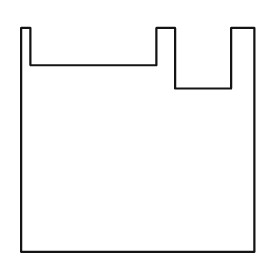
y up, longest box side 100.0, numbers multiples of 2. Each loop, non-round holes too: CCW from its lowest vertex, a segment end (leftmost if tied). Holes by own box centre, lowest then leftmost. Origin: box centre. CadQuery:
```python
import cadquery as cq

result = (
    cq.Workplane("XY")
    .moveTo(-50.0, -48.0)
    .lineTo(50.0, -48.0)
    .lineTo(50.0, 48.0)
    .lineTo(40.0, 48.0)
    .lineTo(40.0, 22.0)
    .lineTo(16.0, 22.0)
    .lineTo(16.0, 48.0)
    .lineTo(8.0, 48.0)
    .lineTo(8.0, 32.0)
    .lineTo(-46.0, 32.0)
    .lineTo(-46.0, 48.0)
    .lineTo(-50.0, 48.0)
    .close()
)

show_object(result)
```